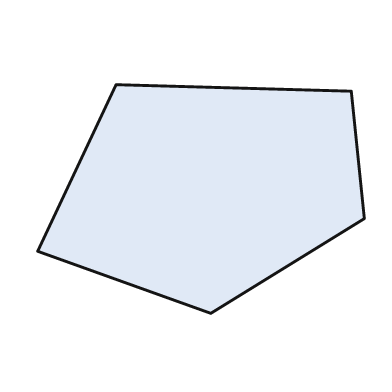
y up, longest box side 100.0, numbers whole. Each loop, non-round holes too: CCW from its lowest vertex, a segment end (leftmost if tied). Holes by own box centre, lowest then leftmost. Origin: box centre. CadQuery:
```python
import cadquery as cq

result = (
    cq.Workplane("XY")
    .moveTo(3.0, -35.0)
    .lineTo(50.0, -6.0)
    .lineTo(46.0, 33.0)
    .lineTo(-26.0, 35.0)
    .lineTo(-50.0, -16.0)
    .close()
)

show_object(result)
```